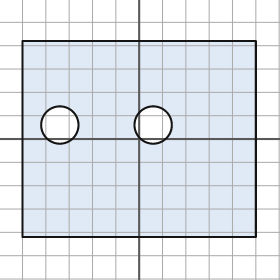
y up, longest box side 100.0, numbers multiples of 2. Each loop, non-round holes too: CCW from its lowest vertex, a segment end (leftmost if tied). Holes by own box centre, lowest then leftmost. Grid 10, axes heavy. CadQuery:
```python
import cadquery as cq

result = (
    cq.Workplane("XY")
    .moveTo(-50.0, -42.0)
    .lineTo(50.0, -42.0)
    .lineTo(50.0, 42.0)
    .lineTo(-50.0, 42.0)
    .close()
    .moveTo(-34.0, 6.0)
    .circle(8.0)
    .moveTo(6.0, 6.0)
    .circle(8.0)
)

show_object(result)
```